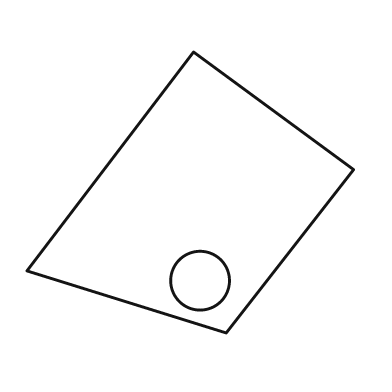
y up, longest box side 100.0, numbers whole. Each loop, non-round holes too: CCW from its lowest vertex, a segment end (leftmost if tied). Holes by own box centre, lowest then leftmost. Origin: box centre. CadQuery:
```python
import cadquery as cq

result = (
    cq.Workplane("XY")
    .moveTo(11.0, -43.0)
    .lineTo(50.0, 7.0)
    .lineTo(1.0, 43.0)
    .lineTo(-50.0, -24.0)
    .close()
    .moveTo(3.0, -27.0)
    .circle(9.0)
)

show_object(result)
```